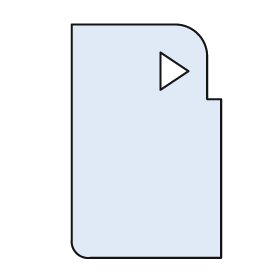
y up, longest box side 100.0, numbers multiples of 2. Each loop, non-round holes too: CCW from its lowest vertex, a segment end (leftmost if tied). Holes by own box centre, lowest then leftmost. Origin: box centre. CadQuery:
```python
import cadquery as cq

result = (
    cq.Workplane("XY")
    .moveTo(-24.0, -50.0)
    .lineTo(32.0, -50.0)
    .lineTo(32.0, 18.0)
    .lineTo(26.0, 18.0)
    .lineTo(26.0, 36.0)
    .threePointArc((22.0, 46.0), (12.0, 50.0))
    .lineTo(-32.0, 50.0)
    .lineTo(-32.0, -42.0)
    .threePointArc((-30.0, -48.0), (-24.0, -50.0))
    .close()
    .moveTo(6.0, 22.0)
    .lineTo(18.0, 30.0)
    .lineTo(6.0, 38.0)
    .close()
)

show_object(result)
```